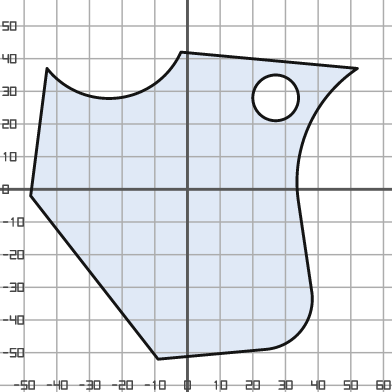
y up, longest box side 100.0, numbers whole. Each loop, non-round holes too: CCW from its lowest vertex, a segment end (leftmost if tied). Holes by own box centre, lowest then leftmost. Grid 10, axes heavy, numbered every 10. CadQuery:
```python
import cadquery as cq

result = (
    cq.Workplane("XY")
    .moveTo(-9.0, -52.0)
    .lineTo(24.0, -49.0)
    .threePointArc((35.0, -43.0), (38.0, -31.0))
    .lineTo(34.0, -4.0)
    .threePointArc((37.0, 19.0), (52.0, 37.0))
    .lineTo(-2.0, 42.0)
    .threePointArc((-21.0, 28.0), (-43.0, 37.0))
    .lineTo(-48.0, -2.0)
    .close()
    .moveTo(27.0, 28.0)
    .circle(7.0)
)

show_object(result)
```